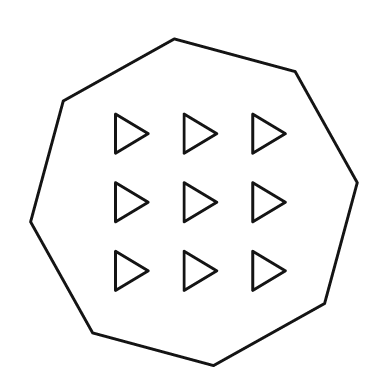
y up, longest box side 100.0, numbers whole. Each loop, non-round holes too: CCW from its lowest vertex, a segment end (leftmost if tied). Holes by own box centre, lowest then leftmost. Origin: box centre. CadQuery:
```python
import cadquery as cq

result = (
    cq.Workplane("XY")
    .moveTo(6.0, -50.0)
    .lineTo(40.0, -31.0)
    .lineTo(50.0, 6.0)
    .lineTo(31.0, 40.0)
    .lineTo(-6.0, 50.0)
    .lineTo(-40.0, 31.0)
    .lineTo(-50.0, -6.0)
    .lineTo(-31.0, -40.0)
    .close()
    .moveTo(-24.0, -27.0)
    .lineTo(-14.0, -21.0)
    .lineTo(-24.0, -15.0)
    .close()
    .moveTo(-3.0, -27.0)
    .lineTo(7.0, -21.0)
    .lineTo(-3.0, -15.0)
    .close()
    .moveTo(18.0, -27.0)
    .lineTo(28.0, -21.0)
    .lineTo(18.0, -15.0)
    .close()
    .moveTo(-24.0, -6.0)
    .lineTo(-14.0, 0.0)
    .lineTo(-24.0, 6.0)
    .close()
    .moveTo(-3.0, -6.0)
    .lineTo(7.0, 0.0)
    .lineTo(-3.0, 6.0)
    .close()
    .moveTo(18.0, -6.0)
    .lineTo(28.0, 0.0)
    .lineTo(18.0, 6.0)
    .close()
    .moveTo(-24.0, 15.0)
    .lineTo(-14.0, 21.0)
    .lineTo(-24.0, 27.0)
    .close()
    .moveTo(-3.0, 15.0)
    .lineTo(7.0, 21.0)
    .lineTo(-3.0, 27.0)
    .close()
    .moveTo(18.0, 15.0)
    .lineTo(28.0, 21.0)
    .lineTo(18.0, 27.0)
    .close()
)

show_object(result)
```